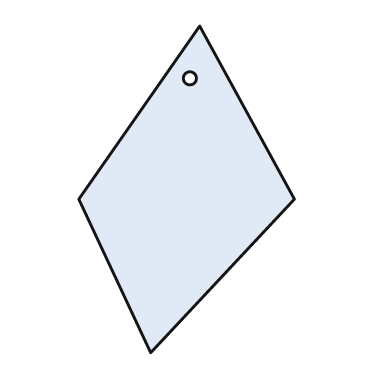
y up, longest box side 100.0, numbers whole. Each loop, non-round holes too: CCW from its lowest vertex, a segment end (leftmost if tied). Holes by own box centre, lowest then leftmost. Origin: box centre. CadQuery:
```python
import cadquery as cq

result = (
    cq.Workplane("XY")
    .moveTo(-11.0, -50.0)
    .lineTo(33.0, -3.0)
    .lineTo(4.0, 50.0)
    .lineTo(-33.0, -3.0)
    .close()
    .moveTo(1.0, 34.0)
    .circle(2.0)
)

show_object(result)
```